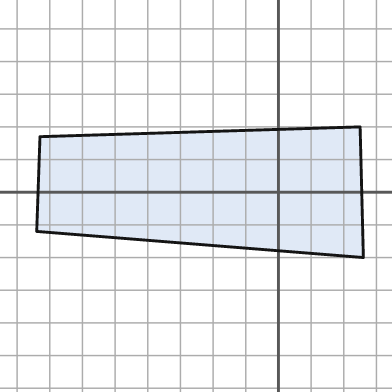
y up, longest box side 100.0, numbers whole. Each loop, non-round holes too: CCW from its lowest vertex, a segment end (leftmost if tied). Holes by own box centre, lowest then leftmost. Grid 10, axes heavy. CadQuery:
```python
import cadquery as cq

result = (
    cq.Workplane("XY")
    .moveTo(26.0, -20.0)
    .lineTo(25.0, 20.0)
    .lineTo(-73.0, 17.0)
    .lineTo(-74.0, -12.0)
    .close()
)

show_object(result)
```